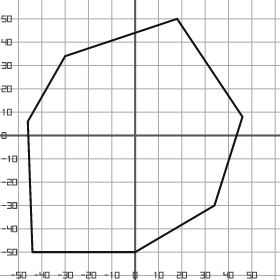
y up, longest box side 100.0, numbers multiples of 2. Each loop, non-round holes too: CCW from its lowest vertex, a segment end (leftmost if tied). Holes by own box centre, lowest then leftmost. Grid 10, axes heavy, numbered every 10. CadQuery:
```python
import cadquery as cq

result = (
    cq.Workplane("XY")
    .moveTo(-44.0, -50.0)
    .lineTo(0.0, -50.0)
    .lineTo(34.0, -30.0)
    .lineTo(46.0, 8.0)
    .lineTo(18.0, 50.0)
    .lineTo(-30.0, 34.0)
    .lineTo(-46.0, 6.0)
    .close()
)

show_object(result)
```